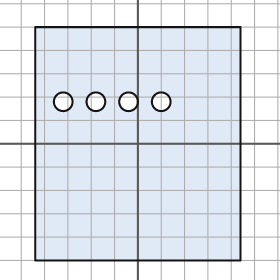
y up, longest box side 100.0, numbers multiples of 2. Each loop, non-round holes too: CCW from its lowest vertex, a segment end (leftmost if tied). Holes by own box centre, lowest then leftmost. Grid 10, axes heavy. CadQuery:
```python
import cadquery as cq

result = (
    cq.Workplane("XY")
    .moveTo(-44.0, -50.0)
    .lineTo(44.0, -50.0)
    .lineTo(44.0, 50.0)
    .lineTo(-44.0, 50.0)
    .close()
    .moveTo(-32.0, 18.0)
    .circle(4.0)
    .moveTo(-18.0, 18.0)
    .circle(4.0)
    .moveTo(-4.0, 18.0)
    .circle(4.0)
    .moveTo(10.0, 18.0)
    .circle(4.0)
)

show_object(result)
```